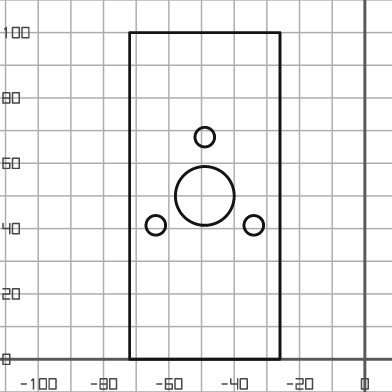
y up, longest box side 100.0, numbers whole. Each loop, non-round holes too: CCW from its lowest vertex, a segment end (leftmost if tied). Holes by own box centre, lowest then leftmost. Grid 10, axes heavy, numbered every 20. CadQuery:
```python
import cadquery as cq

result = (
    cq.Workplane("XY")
    .moveTo(-72.0, 0.0)
    .lineTo(-26.0, 0.0)
    .lineTo(-26.0, 100.0)
    .lineTo(-72.0, 100.0)
    .close()
    .moveTo(-64.0, 41.0)
    .circle(3.0)
    .moveTo(-34.0, 41.0)
    .circle(3.0)
    .moveTo(-49.0, 50.0)
    .circle(9.0)
    .moveTo(-49.0, 68.0)
    .circle(3.0)
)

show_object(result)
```